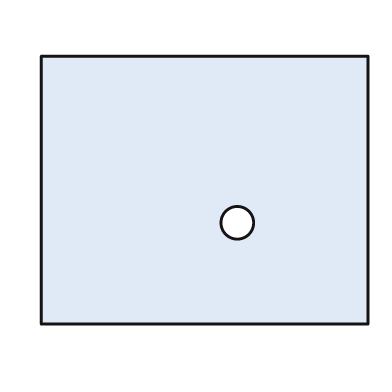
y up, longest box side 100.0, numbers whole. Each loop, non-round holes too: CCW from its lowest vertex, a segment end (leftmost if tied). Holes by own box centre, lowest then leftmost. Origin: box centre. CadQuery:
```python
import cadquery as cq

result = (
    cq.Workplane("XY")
    .moveTo(-50.0, -41.0)
    .lineTo(50.0, -41.0)
    .lineTo(50.0, 41.0)
    .lineTo(-50.0, 41.0)
    .close()
    .moveTo(10.0, -10.0)
    .circle(5.0)
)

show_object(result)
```